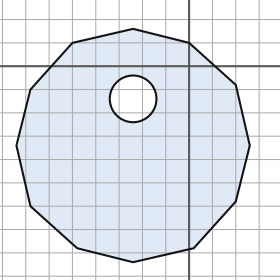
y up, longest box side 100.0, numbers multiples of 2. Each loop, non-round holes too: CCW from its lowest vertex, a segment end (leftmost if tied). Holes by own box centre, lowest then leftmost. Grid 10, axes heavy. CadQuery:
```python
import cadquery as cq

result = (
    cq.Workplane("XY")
    .moveTo(-24.0, -84.0)
    .lineTo(2.0, -78.0)
    .lineTo(20.0, -58.0)
    .lineTo(26.0, -34.0)
    .lineTo(20.0, -8.0)
    .lineTo(0.0, 10.0)
    .lineTo(-24.0, 16.0)
    .lineTo(-50.0, 10.0)
    .lineTo(-68.0, -10.0)
    .lineTo(-74.0, -34.0)
    .lineTo(-68.0, -60.0)
    .lineTo(-48.0, -78.0)
    .close()
    .moveTo(-24.0, -14.0)
    .circle(10.0)
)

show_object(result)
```